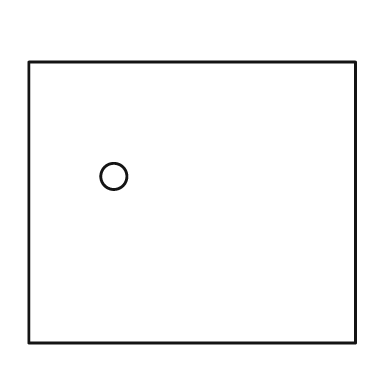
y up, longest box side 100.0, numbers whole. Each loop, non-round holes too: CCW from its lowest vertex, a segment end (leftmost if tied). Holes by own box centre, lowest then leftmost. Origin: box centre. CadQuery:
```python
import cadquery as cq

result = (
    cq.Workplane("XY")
    .moveTo(-50.0, -43.0)
    .lineTo(50.0, -43.0)
    .lineTo(50.0, 43.0)
    .lineTo(-50.0, 43.0)
    .close()
    .moveTo(-24.0, 8.0)
    .circle(4.0)
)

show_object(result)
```